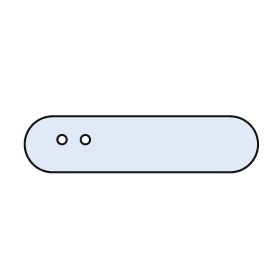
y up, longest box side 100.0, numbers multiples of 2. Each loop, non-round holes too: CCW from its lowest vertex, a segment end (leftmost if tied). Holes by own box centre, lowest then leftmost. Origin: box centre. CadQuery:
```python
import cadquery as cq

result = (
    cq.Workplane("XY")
    .moveTo(-38.0, -12.0)
    .lineTo(38.0, -12.0)
    .threePointArc((50.0, 0.0), (38.0, 12.0))
    .lineTo(-38.0, 12.0)
    .threePointArc((-50.0, 0.0), (-38.0, -12.0))
    .close()
    .moveTo(-34.0, 2.0)
    .circle(2.0)
    .moveTo(-24.0, 2.0)
    .circle(2.0)
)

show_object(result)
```